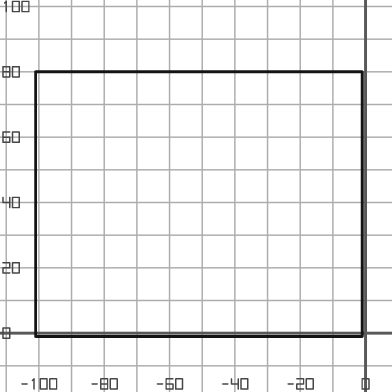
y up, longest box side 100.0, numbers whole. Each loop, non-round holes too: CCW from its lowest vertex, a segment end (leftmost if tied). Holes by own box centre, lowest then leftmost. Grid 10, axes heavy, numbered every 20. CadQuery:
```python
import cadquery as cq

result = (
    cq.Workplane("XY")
    .moveTo(-101.0, -1.0)
    .lineTo(-1.0, -1.0)
    .lineTo(-1.0, 80.0)
    .lineTo(-101.0, 80.0)
    .close()
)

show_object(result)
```